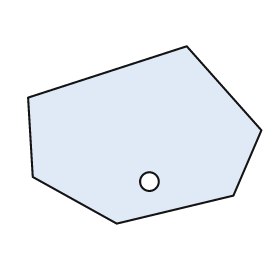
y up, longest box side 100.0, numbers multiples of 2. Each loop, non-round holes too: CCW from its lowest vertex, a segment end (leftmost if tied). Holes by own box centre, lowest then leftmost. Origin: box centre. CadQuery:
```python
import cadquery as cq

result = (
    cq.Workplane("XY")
    .moveTo(-12.0, -38.0)
    .lineTo(38.0, -26.0)
    .lineTo(50.0, 2.0)
    .lineTo(18.0, 38.0)
    .lineTo(-50.0, 16.0)
    .lineTo(-48.0, -18.0)
    .close()
    .moveTo(2.0, -20.0)
    .circle(4.0)
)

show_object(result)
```